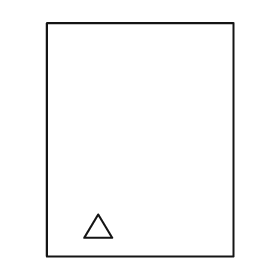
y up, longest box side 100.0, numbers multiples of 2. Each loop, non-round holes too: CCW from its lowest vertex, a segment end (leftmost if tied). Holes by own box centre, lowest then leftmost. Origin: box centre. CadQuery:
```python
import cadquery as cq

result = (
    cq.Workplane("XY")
    .moveTo(-40.0, -50.0)
    .lineTo(40.0, -50.0)
    .lineTo(40.0, 50.0)
    .lineTo(-40.0, 50.0)
    .close()
    .moveTo(-24.0, -42.0)
    .lineTo(-12.0, -42.0)
    .lineTo(-18.0, -32.0)
    .close()
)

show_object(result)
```